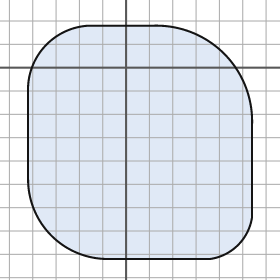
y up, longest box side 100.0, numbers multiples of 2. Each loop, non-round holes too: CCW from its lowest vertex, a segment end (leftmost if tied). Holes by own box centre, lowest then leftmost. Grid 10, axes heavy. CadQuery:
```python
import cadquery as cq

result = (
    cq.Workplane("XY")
    .moveTo(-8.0, -82.0)
    .lineTo(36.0, -82.0)
    .threePointArc((48.0, -76.0), (54.0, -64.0))
    .lineTo(54.0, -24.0)
    .threePointArc((42.0, 6.0), (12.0, 18.0))
    .lineTo(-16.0, 18.0)
    .threePointArc((-34.0, 10.0), (-42.0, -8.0))
    .lineTo(-42.0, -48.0)
    .threePointArc((-32.0, -72.0), (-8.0, -82.0))
    .close()
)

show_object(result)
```